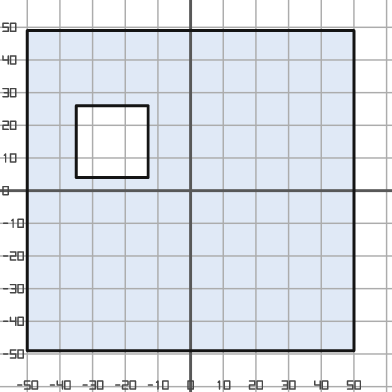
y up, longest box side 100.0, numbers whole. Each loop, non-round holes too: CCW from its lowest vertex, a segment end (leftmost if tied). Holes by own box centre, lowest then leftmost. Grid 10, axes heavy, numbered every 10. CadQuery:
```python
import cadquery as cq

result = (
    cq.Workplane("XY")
    .moveTo(-50.0, -49.0)
    .lineTo(50.0, -49.0)
    .lineTo(50.0, 49.0)
    .lineTo(-50.0, 49.0)
    .close()
    .moveTo(-35.0, 4.0)
    .lineTo(-13.0, 4.0)
    .lineTo(-13.0, 26.0)
    .lineTo(-35.0, 26.0)
    .close()
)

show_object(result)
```